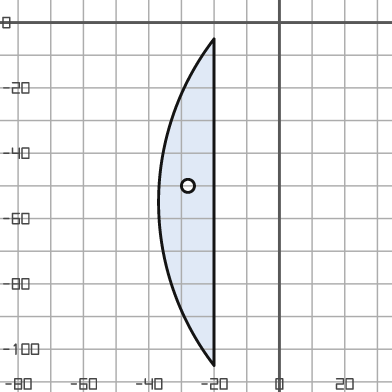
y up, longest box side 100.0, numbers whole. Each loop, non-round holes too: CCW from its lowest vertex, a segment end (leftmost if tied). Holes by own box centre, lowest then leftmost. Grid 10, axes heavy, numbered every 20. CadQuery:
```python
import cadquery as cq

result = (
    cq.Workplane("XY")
    .moveTo(-20.0, -105.0)
    .lineTo(-20.0, -5.0)
    .threePointArc((-37.0, -55.0), (-20.0, -105.0))
    .close()
    .moveTo(-28.0, -50.0)
    .circle(2.0)
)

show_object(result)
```